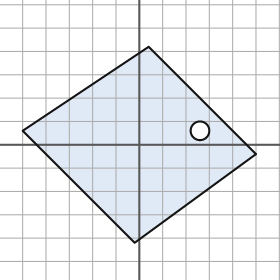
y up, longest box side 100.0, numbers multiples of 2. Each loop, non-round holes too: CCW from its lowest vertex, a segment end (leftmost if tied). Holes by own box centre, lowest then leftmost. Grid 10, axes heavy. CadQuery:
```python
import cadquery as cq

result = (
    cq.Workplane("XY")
    .moveTo(-2.0, -42.0)
    .lineTo(50.0, -4.0)
    .lineTo(4.0, 42.0)
    .lineTo(-50.0, 6.0)
    .close()
    .moveTo(26.0, 6.0)
    .circle(4.0)
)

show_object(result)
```